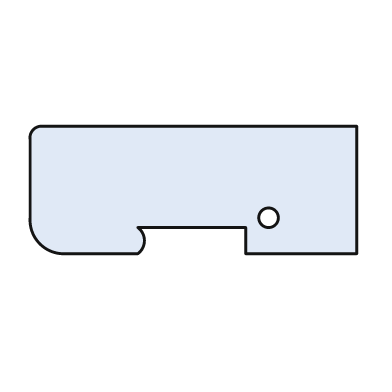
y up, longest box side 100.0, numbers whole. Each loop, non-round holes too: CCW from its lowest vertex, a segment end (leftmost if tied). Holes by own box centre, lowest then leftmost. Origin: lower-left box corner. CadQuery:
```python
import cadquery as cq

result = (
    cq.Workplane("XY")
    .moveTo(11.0, 0.0)
    .lineTo(33.0, 0.0)
    .threePointArc((35.0, 4.0), (33.0, 8.0))
    .lineTo(66.0, 8.0)
    .lineTo(66.0, 0.0)
    .lineTo(100.0, 0.0)
    .lineTo(100.0, 39.0)
    .lineTo(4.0, 39.0)
    .threePointArc((1.0, 38.0), (0.0, 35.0))
    .lineTo(0.0, 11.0)
    .threePointArc((3.0, 3.0), (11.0, 0.0))
    .close()
    .moveTo(73.0, 11.0)
    .circle(3.0)
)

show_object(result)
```